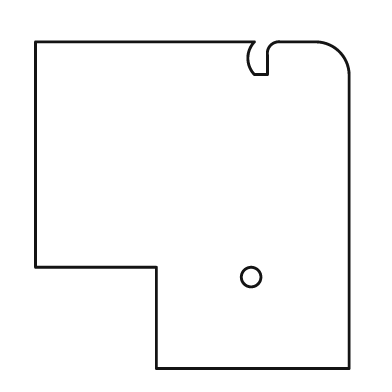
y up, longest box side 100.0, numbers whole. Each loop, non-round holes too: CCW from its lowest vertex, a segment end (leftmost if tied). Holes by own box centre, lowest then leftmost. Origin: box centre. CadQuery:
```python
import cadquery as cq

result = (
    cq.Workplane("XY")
    .moveTo(-11.0, -50.0)
    .lineTo(48.0, -50.0)
    .lineTo(48.0, 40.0)
    .threePointArc((45.0, 47.0), (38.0, 50.0))
    .lineTo(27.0, 50.0)
    .threePointArc((24.0, 49.0), (23.0, 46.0))
    .lineTo(23.0, 40.0)
    .lineTo(19.0, 40.0)
    .threePointArc((17.0, 45.0), (19.0, 50.0))
    .lineTo(-48.0, 50.0)
    .lineTo(-48.0, -19.0)
    .lineTo(-11.0, -19.0)
    .close()
    .moveTo(18.0, -22.0)
    .circle(3.0)
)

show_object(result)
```